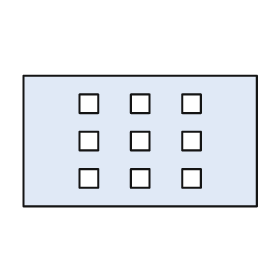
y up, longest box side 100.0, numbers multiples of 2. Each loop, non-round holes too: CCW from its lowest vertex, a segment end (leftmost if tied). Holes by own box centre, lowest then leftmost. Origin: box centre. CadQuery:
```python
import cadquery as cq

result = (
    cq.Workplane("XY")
    .moveTo(-50.0, -28.0)
    .lineTo(50.0, -28.0)
    .lineTo(50.0, 28.0)
    .lineTo(-50.0, 28.0)
    .close()
    .moveTo(-26.0, -20.0)
    .lineTo(-18.0, -20.0)
    .lineTo(-18.0, -12.0)
    .lineTo(-26.0, -12.0)
    .close()
    .moveTo(-4.0, -20.0)
    .lineTo(4.0, -20.0)
    .lineTo(4.0, -12.0)
    .lineTo(-4.0, -12.0)
    .close()
    .moveTo(18.0, -20.0)
    .lineTo(26.0, -20.0)
    .lineTo(26.0, -12.0)
    .lineTo(18.0, -12.0)
    .close()
    .moveTo(-26.0, -4.0)
    .lineTo(-18.0, -4.0)
    .lineTo(-18.0, 4.0)
    .lineTo(-26.0, 4.0)
    .close()
    .moveTo(-4.0, -4.0)
    .lineTo(4.0, -4.0)
    .lineTo(4.0, 4.0)
    .lineTo(-4.0, 4.0)
    .close()
    .moveTo(18.0, -4.0)
    .lineTo(26.0, -4.0)
    .lineTo(26.0, 4.0)
    .lineTo(18.0, 4.0)
    .close()
    .moveTo(-26.0, 12.0)
    .lineTo(-18.0, 12.0)
    .lineTo(-18.0, 20.0)
    .lineTo(-26.0, 20.0)
    .close()
    .moveTo(-4.0, 12.0)
    .lineTo(4.0, 12.0)
    .lineTo(4.0, 20.0)
    .lineTo(-4.0, 20.0)
    .close()
    .moveTo(18.0, 12.0)
    .lineTo(26.0, 12.0)
    .lineTo(26.0, 20.0)
    .lineTo(18.0, 20.0)
    .close()
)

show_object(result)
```